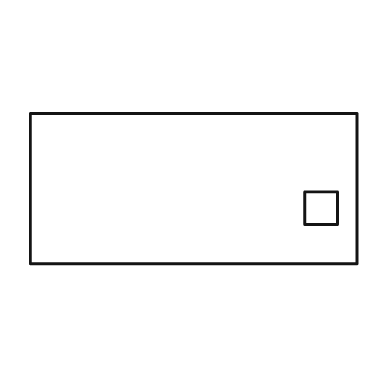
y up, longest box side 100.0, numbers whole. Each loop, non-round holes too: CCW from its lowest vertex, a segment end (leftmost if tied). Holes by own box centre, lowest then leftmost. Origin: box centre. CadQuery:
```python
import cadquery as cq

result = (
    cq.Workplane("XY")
    .moveTo(-50.0, -23.0)
    .lineTo(50.0, -23.0)
    .lineTo(50.0, 23.0)
    .lineTo(-50.0, 23.0)
    .close()
    .moveTo(34.0, -11.0)
    .lineTo(44.0, -11.0)
    .lineTo(44.0, -1.0)
    .lineTo(34.0, -1.0)
    .close()
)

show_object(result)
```